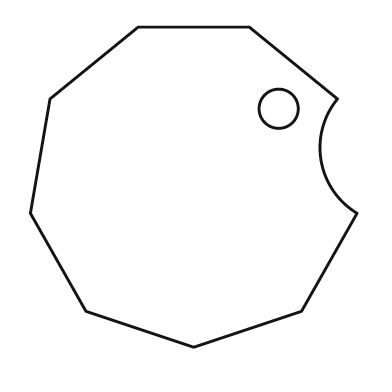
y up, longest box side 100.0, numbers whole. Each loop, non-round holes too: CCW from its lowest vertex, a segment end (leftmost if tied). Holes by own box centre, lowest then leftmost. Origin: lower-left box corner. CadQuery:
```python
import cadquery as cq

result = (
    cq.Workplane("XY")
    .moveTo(50.0, 0.0)
    .lineTo(83.0, 11.0)
    .lineTo(100.0, 41.0)
    .threePointArc((89.0, 57.0), (94.0, 76.0))
    .lineTo(67.0, 98.0)
    .lineTo(33.0, 98.0)
    .lineTo(6.0, 76.0)
    .lineTo(0.0, 41.0)
    .lineTo(17.0, 11.0)
    .close()
    .moveTo(76.0, 73.0)
    .circle(6.0)
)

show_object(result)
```